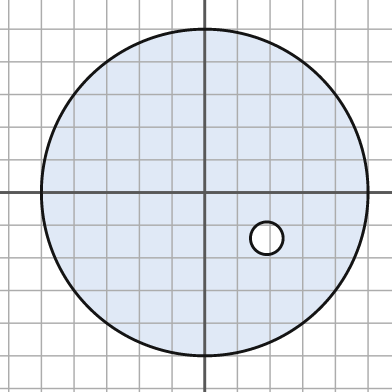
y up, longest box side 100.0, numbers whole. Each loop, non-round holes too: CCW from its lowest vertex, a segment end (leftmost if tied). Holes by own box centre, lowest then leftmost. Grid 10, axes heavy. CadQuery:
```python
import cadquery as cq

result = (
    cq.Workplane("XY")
    .moveTo(0.0, 0.0)
    .circle(50.0)
    .moveTo(19.0, -14.0)
    .circle(5.0)
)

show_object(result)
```